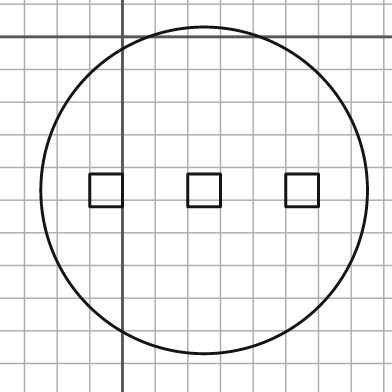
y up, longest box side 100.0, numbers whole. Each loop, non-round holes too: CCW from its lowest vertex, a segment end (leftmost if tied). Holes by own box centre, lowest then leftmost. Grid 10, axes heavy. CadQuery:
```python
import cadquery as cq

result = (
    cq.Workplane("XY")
    .moveTo(25.0, -47.0)
    .circle(50.0)
    .moveTo(-10.0, -52.0)
    .lineTo(0.0, -52.0)
    .lineTo(0.0, -42.0)
    .lineTo(-10.0, -42.0)
    .close()
    .moveTo(20.0, -52.0)
    .lineTo(30.0, -52.0)
    .lineTo(30.0, -42.0)
    .lineTo(20.0, -42.0)
    .close()
    .moveTo(50.0, -52.0)
    .lineTo(60.0, -52.0)
    .lineTo(60.0, -42.0)
    .lineTo(50.0, -42.0)
    .close()
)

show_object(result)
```